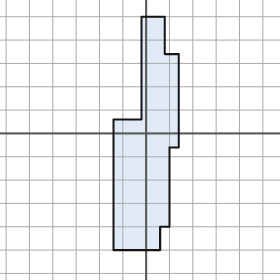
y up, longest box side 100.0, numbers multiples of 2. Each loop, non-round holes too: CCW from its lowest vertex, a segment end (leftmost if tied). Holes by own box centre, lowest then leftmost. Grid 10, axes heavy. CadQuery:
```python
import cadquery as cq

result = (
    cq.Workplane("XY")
    .moveTo(-14.0, -50.0)
    .lineTo(6.0, -50.0)
    .lineTo(6.0, -40.0)
    .lineTo(10.0, -40.0)
    .lineTo(10.0, -6.0)
    .lineTo(14.0, -6.0)
    .lineTo(14.0, 34.0)
    .lineTo(8.0, 34.0)
    .lineTo(8.0, 50.0)
    .lineTo(-2.0, 50.0)
    .lineTo(-2.0, 6.0)
    .lineTo(-14.0, 6.0)
    .close()
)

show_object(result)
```